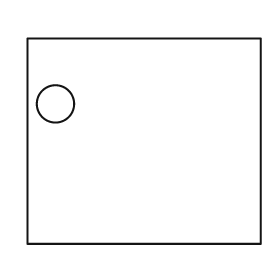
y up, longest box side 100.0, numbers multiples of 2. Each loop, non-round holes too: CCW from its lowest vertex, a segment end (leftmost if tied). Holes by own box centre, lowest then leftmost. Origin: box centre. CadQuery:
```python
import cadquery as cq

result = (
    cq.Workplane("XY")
    .moveTo(-50.0, -44.0)
    .lineTo(50.0, -44.0)
    .lineTo(50.0, 44.0)
    .lineTo(-50.0, 44.0)
    .close()
    .moveTo(-38.0, 16.0)
    .circle(8.0)
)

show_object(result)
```